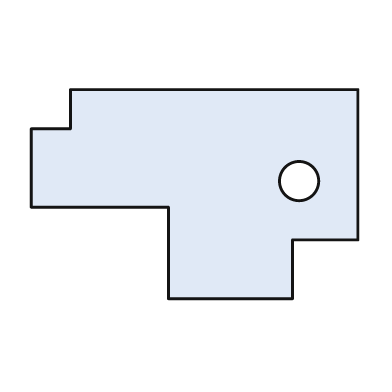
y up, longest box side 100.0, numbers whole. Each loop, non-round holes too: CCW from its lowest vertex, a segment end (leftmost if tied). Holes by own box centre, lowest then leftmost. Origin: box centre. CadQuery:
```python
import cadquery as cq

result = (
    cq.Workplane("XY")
    .moveTo(-8.0, -32.0)
    .lineTo(30.0, -32.0)
    .lineTo(30.0, -14.0)
    .lineTo(50.0, -14.0)
    .lineTo(50.0, 32.0)
    .lineTo(-38.0, 32.0)
    .lineTo(-38.0, 20.0)
    .lineTo(-50.0, 20.0)
    .lineTo(-50.0, -4.0)
    .lineTo(-8.0, -4.0)
    .close()
    .moveTo(32.0, 4.0)
    .circle(6.0)
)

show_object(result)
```